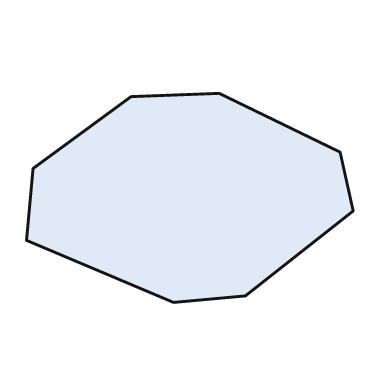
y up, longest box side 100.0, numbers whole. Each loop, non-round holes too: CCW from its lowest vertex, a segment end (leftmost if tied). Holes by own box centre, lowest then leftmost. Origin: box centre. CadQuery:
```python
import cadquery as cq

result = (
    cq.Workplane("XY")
    .moveTo(-5.0, -32.0)
    .lineTo(17.0, -30.0)
    .lineTo(50.0, -4.0)
    .lineTo(46.0, 14.0)
    .lineTo(9.0, 32.0)
    .lineTo(-18.0, 31.0)
    .lineTo(-48.0, 9.0)
    .lineTo(-50.0, -13.0)
    .close()
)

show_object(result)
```